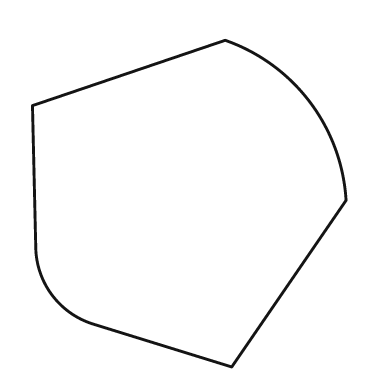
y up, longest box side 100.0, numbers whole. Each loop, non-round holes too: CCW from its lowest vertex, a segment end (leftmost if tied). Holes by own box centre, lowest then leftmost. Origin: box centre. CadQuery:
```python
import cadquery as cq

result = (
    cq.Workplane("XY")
    .moveTo(13.0, -50.0)
    .lineTo(48.0, 1.0)
    .threePointArc((37.0, 31.0), (11.0, 50.0))
    .lineTo(-48.0, 30.0)
    .lineTo(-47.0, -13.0)
    .threePointArc((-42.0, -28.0), (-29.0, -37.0))
    .close()
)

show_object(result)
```